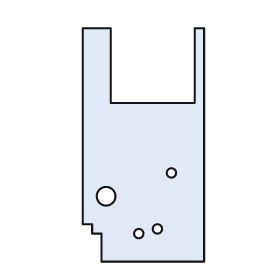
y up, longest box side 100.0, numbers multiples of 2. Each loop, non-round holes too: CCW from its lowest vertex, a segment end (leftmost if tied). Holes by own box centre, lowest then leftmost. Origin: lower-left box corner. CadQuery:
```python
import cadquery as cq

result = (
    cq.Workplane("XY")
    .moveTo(8.0, 0.0)
    .lineTo(52.0, 0.0)
    .lineTo(52.0, 100.0)
    .lineTo(48.0, 100.0)
    .lineTo(48.0, 68.0)
    .lineTo(12.0, 68.0)
    .lineTo(12.0, 100.0)
    .lineTo(0.0, 100.0)
    .lineTo(0.0, 16.0)
    .lineTo(4.0, 16.0)
    .lineTo(4.0, 12.0)
    .lineTo(8.0, 12.0)
    .close()
    .moveTo(24.0, 12.0)
    .circle(2.0)
    .moveTo(32.0, 14.0)
    .circle(2.0)
    .moveTo(10.0, 28.0)
    .circle(4.0)
    .moveTo(38.0, 38.0)
    .circle(2.0)
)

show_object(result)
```